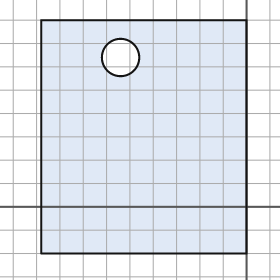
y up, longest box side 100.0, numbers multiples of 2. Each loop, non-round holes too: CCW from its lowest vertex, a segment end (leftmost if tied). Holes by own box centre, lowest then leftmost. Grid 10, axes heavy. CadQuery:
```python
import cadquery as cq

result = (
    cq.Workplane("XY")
    .moveTo(-88.0, -20.0)
    .lineTo(0.0, -20.0)
    .lineTo(0.0, 80.0)
    .lineTo(-88.0, 80.0)
    .close()
    .moveTo(-54.0, 64.0)
    .circle(8.0)
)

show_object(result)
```